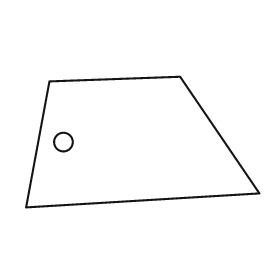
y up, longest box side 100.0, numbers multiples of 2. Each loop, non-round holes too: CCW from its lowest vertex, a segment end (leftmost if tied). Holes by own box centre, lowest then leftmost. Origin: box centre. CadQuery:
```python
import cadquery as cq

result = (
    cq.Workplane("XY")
    .moveTo(-50.0, -28.0)
    .lineTo(50.0, -22.0)
    .lineTo(16.0, 28.0)
    .lineTo(-40.0, 26.0)
    .close()
    .moveTo(-34.0, 0.0)
    .circle(4.0)
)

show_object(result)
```